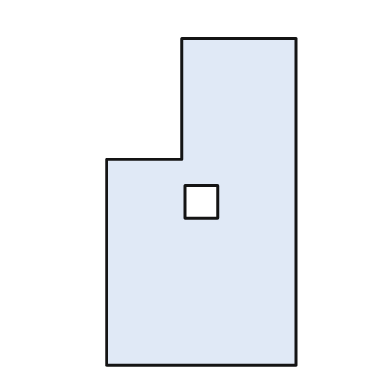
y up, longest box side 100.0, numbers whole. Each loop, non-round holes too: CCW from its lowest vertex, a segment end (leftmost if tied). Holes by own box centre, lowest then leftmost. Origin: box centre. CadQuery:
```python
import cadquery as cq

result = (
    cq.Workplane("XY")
    .moveTo(-29.0, -50.0)
    .lineTo(29.0, -50.0)
    .lineTo(29.0, 50.0)
    .lineTo(-6.0, 50.0)
    .lineTo(-6.0, 13.0)
    .lineTo(-29.0, 13.0)
    .close()
    .moveTo(-5.0, -5.0)
    .lineTo(5.0, -5.0)
    .lineTo(5.0, 5.0)
    .lineTo(-5.0, 5.0)
    .close()
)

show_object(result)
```